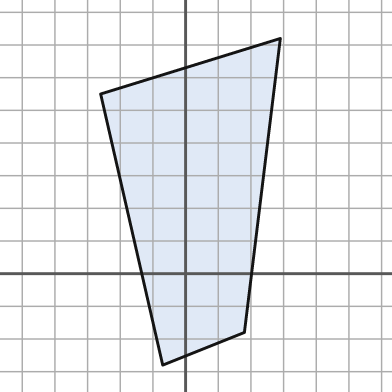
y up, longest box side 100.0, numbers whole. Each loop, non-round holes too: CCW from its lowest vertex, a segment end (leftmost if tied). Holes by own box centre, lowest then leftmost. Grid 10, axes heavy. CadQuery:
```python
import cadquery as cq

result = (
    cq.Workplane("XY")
    .moveTo(-7.0, -28.0)
    .lineTo(18.0, -18.0)
    .lineTo(29.0, 72.0)
    .lineTo(-26.0, 55.0)
    .close()
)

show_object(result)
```